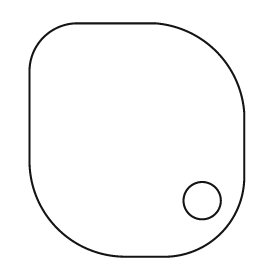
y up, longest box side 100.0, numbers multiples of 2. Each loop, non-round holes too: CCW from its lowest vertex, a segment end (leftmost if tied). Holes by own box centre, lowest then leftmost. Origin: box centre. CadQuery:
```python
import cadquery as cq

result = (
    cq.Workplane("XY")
    .moveTo(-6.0, -50.0)
    .lineTo(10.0, -50.0)
    .threePointArc((36.0, -40.0), (46.0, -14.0))
    .lineTo(46.0, 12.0)
    .threePointArc((34.0, 38.0), (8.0, 50.0))
    .lineTo(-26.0, 50.0)
    .threePointArc((-40.0, 44.0), (-46.0, 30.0))
    .lineTo(-46.0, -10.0)
    .threePointArc((-34.0, -38.0), (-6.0, -50.0))
    .close()
    .moveTo(28.0, -26.0)
    .circle(8.0)
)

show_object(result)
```